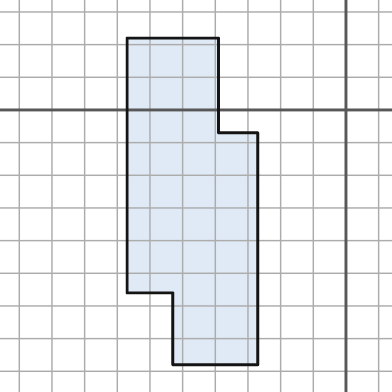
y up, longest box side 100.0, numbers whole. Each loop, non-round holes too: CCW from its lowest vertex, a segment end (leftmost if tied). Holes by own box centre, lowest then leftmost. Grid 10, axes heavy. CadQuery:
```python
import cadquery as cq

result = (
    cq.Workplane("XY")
    .moveTo(-53.0, -78.0)
    .lineTo(-27.0, -78.0)
    .lineTo(-27.0, -7.0)
    .lineTo(-39.0, -7.0)
    .lineTo(-39.0, 22.0)
    .lineTo(-67.0, 22.0)
    .lineTo(-67.0, -56.0)
    .lineTo(-53.0, -56.0)
    .close()
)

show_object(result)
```